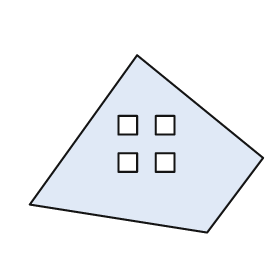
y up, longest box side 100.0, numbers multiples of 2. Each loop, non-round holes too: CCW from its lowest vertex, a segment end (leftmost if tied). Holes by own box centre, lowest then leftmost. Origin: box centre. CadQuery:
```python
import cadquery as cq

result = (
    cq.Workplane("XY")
    .moveTo(26.0, -38.0)
    .lineTo(50.0, -6.0)
    .lineTo(-4.0, 38.0)
    .lineTo(-50.0, -26.0)
    .close()
    .moveTo(-12.0, -12.0)
    .lineTo(-4.0, -12.0)
    .lineTo(-4.0, -4.0)
    .lineTo(-12.0, -4.0)
    .close()
    .moveTo(4.0, -12.0)
    .lineTo(12.0, -12.0)
    .lineTo(12.0, -4.0)
    .lineTo(4.0, -4.0)
    .close()
    .moveTo(-12.0, 4.0)
    .lineTo(-4.0, 4.0)
    .lineTo(-4.0, 12.0)
    .lineTo(-12.0, 12.0)
    .close()
    .moveTo(4.0, 4.0)
    .lineTo(12.0, 4.0)
    .lineTo(12.0, 12.0)
    .lineTo(4.0, 12.0)
    .close()
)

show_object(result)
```